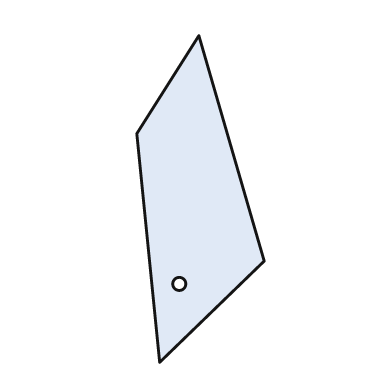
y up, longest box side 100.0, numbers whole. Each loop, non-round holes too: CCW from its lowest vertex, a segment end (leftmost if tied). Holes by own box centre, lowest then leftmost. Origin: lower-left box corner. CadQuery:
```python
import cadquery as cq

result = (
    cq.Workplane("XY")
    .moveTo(7.0, 0.0)
    .lineTo(39.0, 31.0)
    .lineTo(19.0, 100.0)
    .lineTo(0.0, 70.0)
    .close()
    .moveTo(13.0, 24.0)
    .circle(2.0)
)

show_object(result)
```